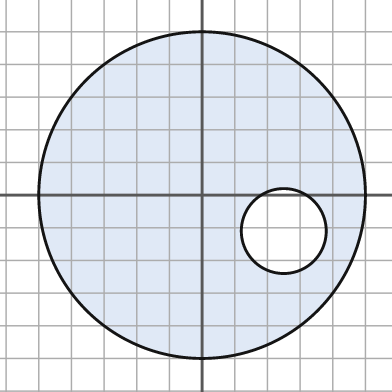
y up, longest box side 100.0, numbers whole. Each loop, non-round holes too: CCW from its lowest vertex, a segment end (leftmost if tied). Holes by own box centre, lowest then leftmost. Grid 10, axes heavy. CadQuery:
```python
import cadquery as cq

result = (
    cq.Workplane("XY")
    .moveTo(0.0, 0.0)
    .circle(50.0)
    .moveTo(25.0, -11.0)
    .circle(13.0)
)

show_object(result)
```